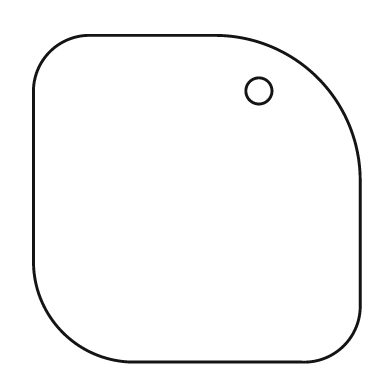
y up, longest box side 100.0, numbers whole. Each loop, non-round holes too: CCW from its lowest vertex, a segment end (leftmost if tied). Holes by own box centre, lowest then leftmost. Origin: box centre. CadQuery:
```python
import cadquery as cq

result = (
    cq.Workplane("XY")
    .moveTo(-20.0, -50.0)
    .lineTo(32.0, -50.0)
    .threePointArc((45.0, -45.0), (50.0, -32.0))
    .lineTo(50.0, 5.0)
    .threePointArc((37.0, 37.0), (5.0, 50.0))
    .lineTo(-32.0, 50.0)
    .threePointArc((-45.0, 45.0), (-50.0, 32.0))
    .lineTo(-50.0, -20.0)
    .threePointArc((-41.0, -41.0), (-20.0, -50.0))
    .close()
    .moveTo(19.0, 33.0)
    .circle(4.0)
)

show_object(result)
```